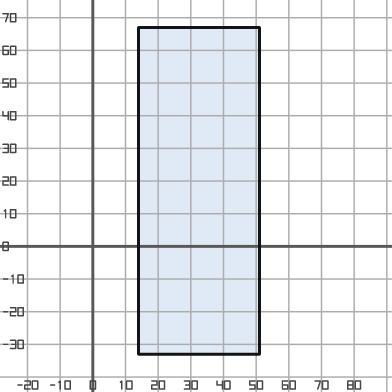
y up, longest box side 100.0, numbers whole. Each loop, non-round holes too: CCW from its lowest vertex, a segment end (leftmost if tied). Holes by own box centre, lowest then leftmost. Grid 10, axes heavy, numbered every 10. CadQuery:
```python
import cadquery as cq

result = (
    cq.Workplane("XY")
    .moveTo(14.0, -33.0)
    .lineTo(51.0, -33.0)
    .lineTo(51.0, 67.0)
    .lineTo(14.0, 67.0)
    .close()
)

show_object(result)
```